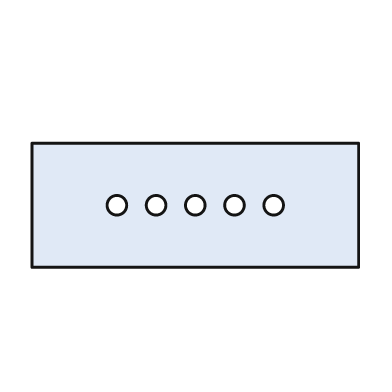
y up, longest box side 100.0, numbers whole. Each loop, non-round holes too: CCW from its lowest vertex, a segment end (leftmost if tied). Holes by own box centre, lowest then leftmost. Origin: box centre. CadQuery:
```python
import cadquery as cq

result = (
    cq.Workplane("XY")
    .moveTo(-50.0, -19.0)
    .lineTo(50.0, -19.0)
    .lineTo(50.0, 19.0)
    .lineTo(-50.0, 19.0)
    .close()
    .moveTo(-24.0, 0.0)
    .circle(3.0)
    .moveTo(-12.0, 0.0)
    .circle(3.0)
    .moveTo(0.0, 0.0)
    .circle(3.0)
    .moveTo(12.0, 0.0)
    .circle(3.0)
    .moveTo(24.0, 0.0)
    .circle(3.0)
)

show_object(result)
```